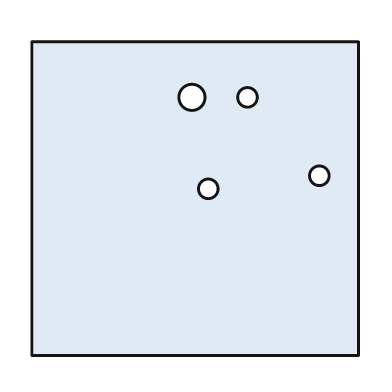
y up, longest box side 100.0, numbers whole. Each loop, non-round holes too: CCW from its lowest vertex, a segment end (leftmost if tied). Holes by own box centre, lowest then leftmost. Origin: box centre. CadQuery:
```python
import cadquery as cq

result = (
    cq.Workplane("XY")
    .moveTo(-50.0, -48.0)
    .lineTo(50.0, -48.0)
    .lineTo(50.0, 48.0)
    .lineTo(-50.0, 48.0)
    .close()
    .moveTo(4.0, 3.0)
    .circle(3.0)
    .moveTo(38.0, 7.0)
    .circle(3.0)
    .moveTo(-1.0, 31.0)
    .circle(4.0)
    .moveTo(16.0, 31.0)
    .circle(3.0)
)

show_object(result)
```